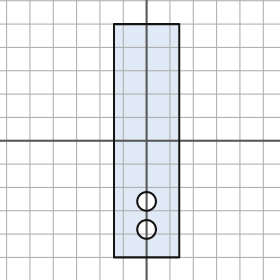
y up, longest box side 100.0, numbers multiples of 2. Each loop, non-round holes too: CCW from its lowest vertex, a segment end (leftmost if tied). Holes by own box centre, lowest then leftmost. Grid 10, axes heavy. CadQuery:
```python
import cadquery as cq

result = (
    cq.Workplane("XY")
    .moveTo(-14.0, -50.0)
    .lineTo(14.0, -50.0)
    .lineTo(14.0, 50.0)
    .lineTo(-14.0, 50.0)
    .close()
    .moveTo(0.0, -38.0)
    .circle(4.0)
    .moveTo(0.0, -26.0)
    .circle(4.0)
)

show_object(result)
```